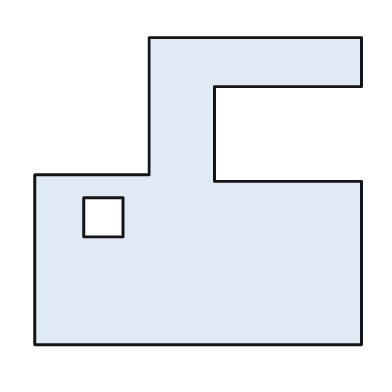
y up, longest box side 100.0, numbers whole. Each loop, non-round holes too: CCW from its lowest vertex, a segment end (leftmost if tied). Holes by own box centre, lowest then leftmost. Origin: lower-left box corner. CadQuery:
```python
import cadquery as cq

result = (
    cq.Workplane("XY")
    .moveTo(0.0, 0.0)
    .lineTo(100.0, 0.0)
    .lineTo(100.0, 50.0)
    .lineTo(55.0, 50.0)
    .lineTo(55.0, 79.0)
    .lineTo(100.0, 79.0)
    .lineTo(100.0, 94.0)
    .lineTo(35.0, 94.0)
    .lineTo(35.0, 52.0)
    .lineTo(0.0, 52.0)
    .close()
    .moveTo(15.0, 33.0)
    .lineTo(27.0, 33.0)
    .lineTo(27.0, 45.0)
    .lineTo(15.0, 45.0)
    .close()
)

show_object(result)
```